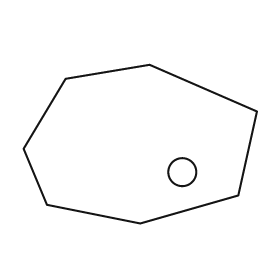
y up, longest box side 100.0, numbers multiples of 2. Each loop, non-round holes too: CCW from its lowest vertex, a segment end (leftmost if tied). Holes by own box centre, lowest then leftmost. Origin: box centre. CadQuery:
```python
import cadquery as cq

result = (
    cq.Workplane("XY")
    .moveTo(0.0, -34.0)
    .lineTo(42.0, -22.0)
    .lineTo(50.0, 14.0)
    .lineTo(4.0, 34.0)
    .lineTo(-32.0, 28.0)
    .lineTo(-50.0, -2.0)
    .lineTo(-40.0, -26.0)
    .close()
    .moveTo(18.0, -12.0)
    .circle(6.0)
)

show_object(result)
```